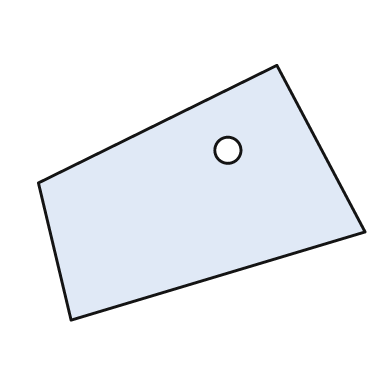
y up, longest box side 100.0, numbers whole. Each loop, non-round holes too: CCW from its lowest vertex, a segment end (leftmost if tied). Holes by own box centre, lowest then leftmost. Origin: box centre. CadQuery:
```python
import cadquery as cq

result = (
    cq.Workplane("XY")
    .moveTo(-40.0, -39.0)
    .lineTo(50.0, -12.0)
    .lineTo(23.0, 39.0)
    .lineTo(-50.0, 3.0)
    .close()
    .moveTo(8.0, 13.0)
    .circle(4.0)
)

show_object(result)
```